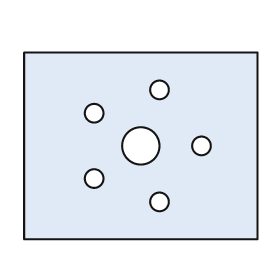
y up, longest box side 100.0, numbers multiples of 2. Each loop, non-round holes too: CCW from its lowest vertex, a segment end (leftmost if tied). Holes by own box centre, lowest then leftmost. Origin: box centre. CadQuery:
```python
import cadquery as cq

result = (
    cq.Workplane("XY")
    .moveTo(-50.0, -40.0)
    .lineTo(50.0, -40.0)
    .lineTo(50.0, 40.0)
    .lineTo(-50.0, 40.0)
    .close()
    .moveTo(8.0, -24.0)
    .circle(4.0)
    .moveTo(-20.0, -14.0)
    .circle(4.0)
    .moveTo(0.0, 0.0)
    .circle(8.0)
    .moveTo(26.0, 0.0)
    .circle(4.0)
    .moveTo(-20.0, 14.0)
    .circle(4.0)
    .moveTo(8.0, 24.0)
    .circle(4.0)
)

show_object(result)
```